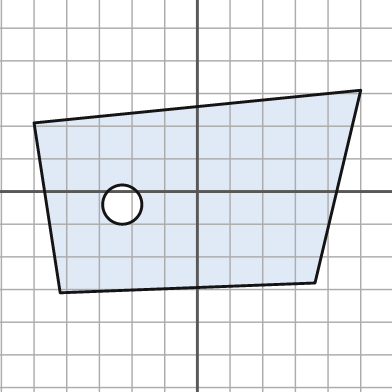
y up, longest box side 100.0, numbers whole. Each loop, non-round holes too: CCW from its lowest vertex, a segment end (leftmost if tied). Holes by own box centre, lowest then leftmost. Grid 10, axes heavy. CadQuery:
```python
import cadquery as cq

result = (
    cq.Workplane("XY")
    .moveTo(-42.0, -31.0)
    .lineTo(36.0, -28.0)
    .lineTo(50.0, 31.0)
    .lineTo(-50.0, 21.0)
    .close()
    .moveTo(-23.0, -4.0)
    .circle(6.0)
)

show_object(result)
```